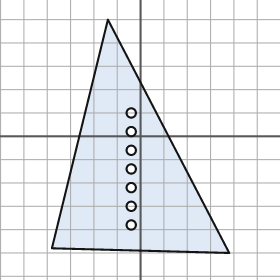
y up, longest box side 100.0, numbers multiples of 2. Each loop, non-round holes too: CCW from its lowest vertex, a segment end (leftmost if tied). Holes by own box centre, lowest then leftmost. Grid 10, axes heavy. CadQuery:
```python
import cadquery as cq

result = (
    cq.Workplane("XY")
    .moveTo(38.0, -50.0)
    .lineTo(-14.0, 50.0)
    .lineTo(-38.0, -48.0)
    .close()
    .moveTo(-4.0, -38.0)
    .circle(2.0)
    .moveTo(-4.0, -30.0)
    .circle(2.0)
    .moveTo(-4.0, -22.0)
    .circle(2.0)
    .moveTo(-4.0, -14.0)
    .circle(2.0)
    .moveTo(-4.0, -6.0)
    .circle(2.0)
    .moveTo(-4.0, 2.0)
    .circle(2.0)
    .moveTo(-4.0, 10.0)
    .circle(2.0)
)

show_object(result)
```